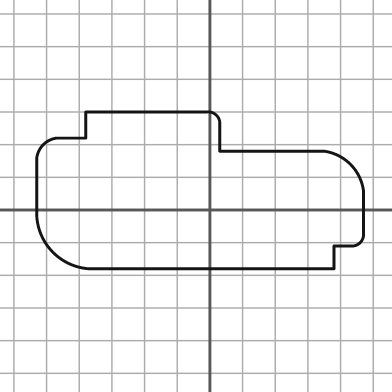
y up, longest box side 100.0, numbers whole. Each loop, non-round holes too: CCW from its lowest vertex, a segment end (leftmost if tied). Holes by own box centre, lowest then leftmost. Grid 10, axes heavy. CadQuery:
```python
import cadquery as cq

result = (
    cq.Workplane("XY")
    .moveTo(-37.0, -18.0)
    .lineTo(38.0, -18.0)
    .lineTo(38.0, -11.0)
    .lineTo(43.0, -11.0)
    .threePointArc((46.0, -10.0), (47.0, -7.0))
    .lineTo(47.0, 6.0)
    .threePointArc((43.0, 14.0), (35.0, 18.0))
    .lineTo(3.0, 18.0)
    .lineTo(3.0, 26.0)
    .threePointArc((2.0, 29.0), (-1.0, 30.0))
    .lineTo(-38.0, 30.0)
    .lineTo(-38.0, 22.0)
    .lineTo(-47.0, 22.0)
    .threePointArc((-51.0, 20.0), (-53.0, 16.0))
    .lineTo(-53.0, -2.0)
    .threePointArc((-48.0, -13.0), (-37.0, -18.0))
    .close()
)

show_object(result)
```